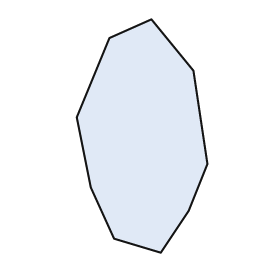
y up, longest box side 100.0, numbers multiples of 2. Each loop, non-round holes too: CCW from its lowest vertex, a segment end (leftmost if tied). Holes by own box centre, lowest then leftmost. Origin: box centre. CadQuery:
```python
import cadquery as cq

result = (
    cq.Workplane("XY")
    .moveTo(8.0, -50.0)
    .lineTo(20.0, -32.0)
    .lineTo(28.0, -12.0)
    .lineTo(22.0, 28.0)
    .lineTo(4.0, 50.0)
    .lineTo(-14.0, 42.0)
    .lineTo(-28.0, 8.0)
    .lineTo(-22.0, -22.0)
    .lineTo(-12.0, -44.0)
    .close()
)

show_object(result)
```